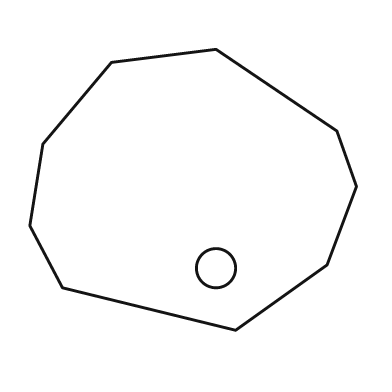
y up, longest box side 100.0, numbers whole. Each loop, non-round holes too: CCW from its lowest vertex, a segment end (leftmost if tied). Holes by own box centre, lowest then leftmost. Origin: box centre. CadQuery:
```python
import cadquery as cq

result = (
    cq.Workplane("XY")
    .moveTo(13.0, -43.0)
    .lineTo(41.0, -23.0)
    .lineTo(50.0, 1.0)
    .lineTo(44.0, 18.0)
    .lineTo(7.0, 43.0)
    .lineTo(-25.0, 39.0)
    .lineTo(-46.0, 14.0)
    .lineTo(-50.0, -11.0)
    .lineTo(-40.0, -30.0)
    .close()
    .moveTo(7.0, -24.0)
    .circle(6.0)
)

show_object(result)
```